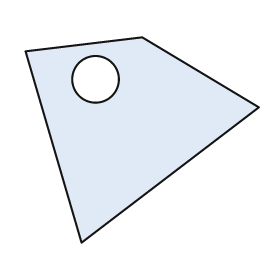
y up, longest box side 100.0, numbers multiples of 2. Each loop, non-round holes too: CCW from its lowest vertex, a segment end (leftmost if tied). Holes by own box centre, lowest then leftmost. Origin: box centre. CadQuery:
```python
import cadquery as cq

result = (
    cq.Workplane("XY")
    .moveTo(-26.0, -44.0)
    .lineTo(50.0, 14.0)
    .lineTo(0.0, 44.0)
    .lineTo(-50.0, 38.0)
    .close()
    .moveTo(-20.0, 26.0)
    .circle(10.0)
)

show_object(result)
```